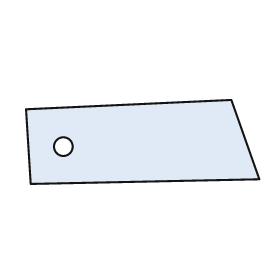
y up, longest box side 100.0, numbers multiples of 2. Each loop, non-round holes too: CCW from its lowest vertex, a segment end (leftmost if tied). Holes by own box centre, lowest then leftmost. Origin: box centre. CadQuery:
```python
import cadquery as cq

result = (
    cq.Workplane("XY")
    .moveTo(-48.0, -18.0)
    .lineTo(50.0, -16.0)
    .lineTo(38.0, 18.0)
    .lineTo(-50.0, 14.0)
    .close()
    .moveTo(-34.0, -2.0)
    .circle(4.0)
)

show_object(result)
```